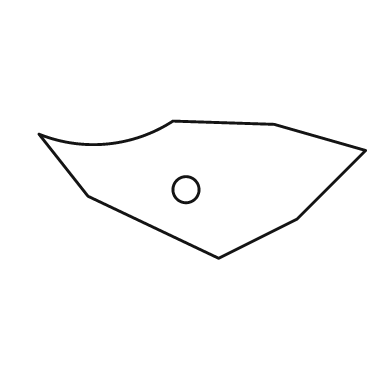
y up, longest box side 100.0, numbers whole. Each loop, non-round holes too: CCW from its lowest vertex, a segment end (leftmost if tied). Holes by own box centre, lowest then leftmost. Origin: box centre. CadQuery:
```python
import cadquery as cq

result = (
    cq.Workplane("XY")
    .moveTo(5.0, -21.0)
    .lineTo(29.0, -9.0)
    .lineTo(50.0, 12.0)
    .lineTo(22.0, 20.0)
    .lineTo(-9.0, 21.0)
    .threePointArc((-29.0, 14.0), (-50.0, 17.0))
    .lineTo(-35.0, -2.0)
    .close()
    .moveTo(-5.0, 0.0)
    .circle(4.0)
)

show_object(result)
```